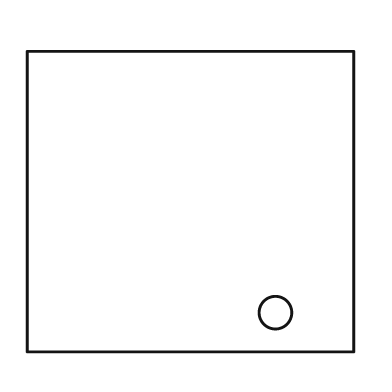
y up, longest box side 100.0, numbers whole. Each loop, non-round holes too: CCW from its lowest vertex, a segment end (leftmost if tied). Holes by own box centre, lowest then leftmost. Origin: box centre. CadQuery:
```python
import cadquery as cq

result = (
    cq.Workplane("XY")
    .moveTo(-50.0, -46.0)
    .lineTo(50.0, -46.0)
    .lineTo(50.0, 46.0)
    .lineTo(-50.0, 46.0)
    .close()
    .moveTo(26.0, -34.0)
    .circle(5.0)
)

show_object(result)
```